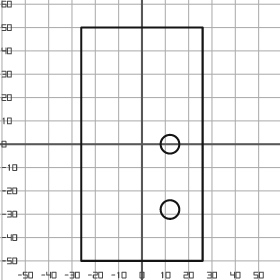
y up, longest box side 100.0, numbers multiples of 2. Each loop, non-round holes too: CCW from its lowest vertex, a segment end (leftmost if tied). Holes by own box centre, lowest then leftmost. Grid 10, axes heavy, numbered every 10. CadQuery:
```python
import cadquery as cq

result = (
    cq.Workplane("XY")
    .moveTo(-26.0, -50.0)
    .lineTo(26.0, -50.0)
    .lineTo(26.0, 50.0)
    .lineTo(-26.0, 50.0)
    .close()
    .moveTo(12.0, -28.0)
    .circle(4.0)
    .moveTo(12.0, 0.0)
    .circle(4.0)
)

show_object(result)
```